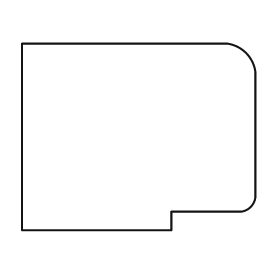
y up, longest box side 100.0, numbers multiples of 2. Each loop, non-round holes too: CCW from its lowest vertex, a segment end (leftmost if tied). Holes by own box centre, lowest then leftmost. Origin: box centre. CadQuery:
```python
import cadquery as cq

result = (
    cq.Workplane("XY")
    .moveTo(-50.0, -40.0)
    .lineTo(14.0, -40.0)
    .lineTo(14.0, -32.0)
    .lineTo(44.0, -32.0)
    .threePointArc((48.0, -30.0), (50.0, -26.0))
    .lineTo(50.0, 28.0)
    .threePointArc((46.0, 36.0), (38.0, 40.0))
    .lineTo(-50.0, 40.0)
    .close()
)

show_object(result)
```